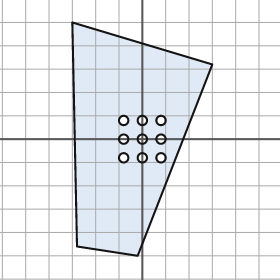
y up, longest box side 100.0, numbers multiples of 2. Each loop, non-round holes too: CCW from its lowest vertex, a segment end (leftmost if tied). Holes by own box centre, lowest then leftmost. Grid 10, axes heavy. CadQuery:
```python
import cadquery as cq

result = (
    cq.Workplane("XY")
    .moveTo(-2.0, -50.0)
    .lineTo(30.0, 32.0)
    .lineTo(-30.0, 50.0)
    .lineTo(-28.0, -46.0)
    .close()
    .moveTo(-8.0, -8.0)
    .circle(2.0)
    .moveTo(0.0, -8.0)
    .circle(2.0)
    .moveTo(8.0, -8.0)
    .circle(2.0)
    .moveTo(-8.0, 0.0)
    .circle(2.0)
    .moveTo(0.0, 0.0)
    .circle(2.0)
    .moveTo(8.0, 0.0)
    .circle(2.0)
    .moveTo(-8.0, 8.0)
    .circle(2.0)
    .moveTo(0.0, 8.0)
    .circle(2.0)
    .moveTo(8.0, 8.0)
    .circle(2.0)
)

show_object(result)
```